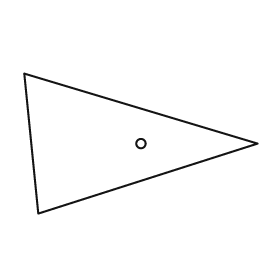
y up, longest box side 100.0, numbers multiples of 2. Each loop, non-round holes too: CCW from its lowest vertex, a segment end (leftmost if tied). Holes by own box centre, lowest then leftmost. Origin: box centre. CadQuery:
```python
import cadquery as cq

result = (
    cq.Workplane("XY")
    .moveTo(-44.0, -30.0)
    .lineTo(50.0, 0.0)
    .lineTo(-50.0, 30.0)
    .close()
    .moveTo(0.0, 0.0)
    .circle(2.0)
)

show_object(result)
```